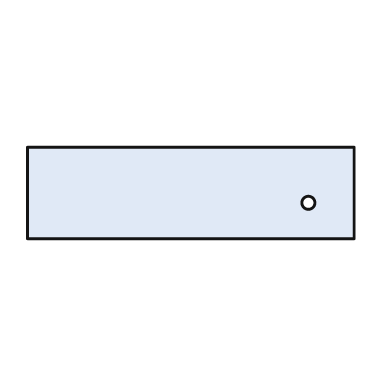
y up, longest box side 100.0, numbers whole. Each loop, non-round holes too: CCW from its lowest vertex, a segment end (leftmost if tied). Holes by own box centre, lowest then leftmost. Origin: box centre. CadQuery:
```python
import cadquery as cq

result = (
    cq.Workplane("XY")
    .moveTo(-50.0, -14.0)
    .lineTo(50.0, -14.0)
    .lineTo(50.0, 14.0)
    .lineTo(-50.0, 14.0)
    .close()
    .moveTo(36.0, -3.0)
    .circle(2.0)
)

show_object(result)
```